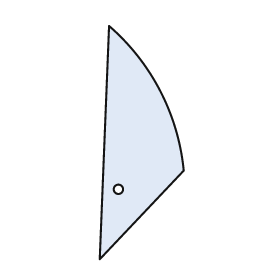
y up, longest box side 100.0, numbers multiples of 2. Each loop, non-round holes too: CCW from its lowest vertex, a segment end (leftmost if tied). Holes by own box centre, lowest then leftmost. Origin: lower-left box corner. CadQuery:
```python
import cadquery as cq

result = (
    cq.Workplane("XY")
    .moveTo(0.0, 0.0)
    .lineTo(36.0, 38.0)
    .threePointArc((26.0, 72.0), (4.0, 100.0))
    .close()
    .moveTo(8.0, 30.0)
    .circle(2.0)
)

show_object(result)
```